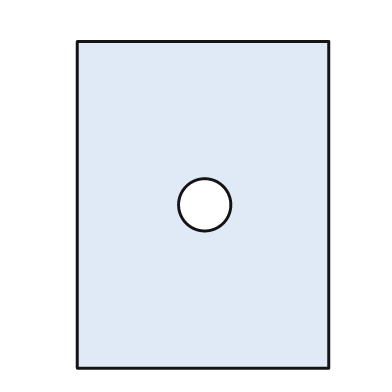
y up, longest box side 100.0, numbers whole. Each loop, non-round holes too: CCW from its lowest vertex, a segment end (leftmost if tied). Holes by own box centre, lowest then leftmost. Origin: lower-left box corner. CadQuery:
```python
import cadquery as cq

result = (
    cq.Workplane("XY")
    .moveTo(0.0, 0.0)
    .lineTo(77.0, 0.0)
    .lineTo(77.0, 100.0)
    .lineTo(0.0, 100.0)
    .close()
    .moveTo(39.0, 50.0)
    .circle(8.0)
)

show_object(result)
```